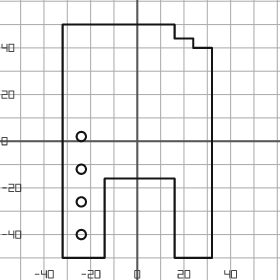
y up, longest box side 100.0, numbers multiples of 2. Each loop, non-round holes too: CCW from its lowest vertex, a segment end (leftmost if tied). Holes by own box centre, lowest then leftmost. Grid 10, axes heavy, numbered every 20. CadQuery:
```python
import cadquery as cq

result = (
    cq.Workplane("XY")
    .moveTo(-32.0, -50.0)
    .lineTo(-14.0, -50.0)
    .lineTo(-14.0, -16.0)
    .lineTo(16.0, -16.0)
    .lineTo(16.0, -50.0)
    .lineTo(32.0, -50.0)
    .lineTo(32.0, 40.0)
    .lineTo(24.0, 40.0)
    .lineTo(24.0, 44.0)
    .lineTo(16.0, 44.0)
    .lineTo(16.0, 50.0)
    .lineTo(-32.0, 50.0)
    .close()
    .moveTo(-24.0, -40.0)
    .circle(2.0)
    .moveTo(-24.0, -26.0)
    .circle(2.0)
    .moveTo(-24.0, -12.0)
    .circle(2.0)
    .moveTo(-24.0, 2.0)
    .circle(2.0)
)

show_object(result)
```